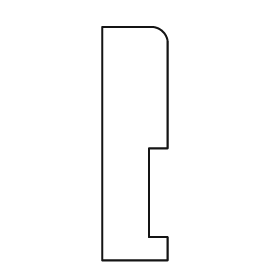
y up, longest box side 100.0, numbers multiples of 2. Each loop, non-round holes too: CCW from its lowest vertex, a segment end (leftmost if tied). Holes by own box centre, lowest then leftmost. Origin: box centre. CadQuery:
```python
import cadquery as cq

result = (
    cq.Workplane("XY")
    .moveTo(-14.0, -50.0)
    .lineTo(14.0, -50.0)
    .lineTo(14.0, -40.0)
    .lineTo(6.0, -40.0)
    .lineTo(6.0, -2.0)
    .lineTo(14.0, -2.0)
    .lineTo(14.0, 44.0)
    .threePointArc((12.0, 48.0), (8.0, 50.0))
    .lineTo(-14.0, 50.0)
    .close()
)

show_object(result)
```